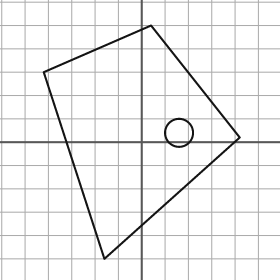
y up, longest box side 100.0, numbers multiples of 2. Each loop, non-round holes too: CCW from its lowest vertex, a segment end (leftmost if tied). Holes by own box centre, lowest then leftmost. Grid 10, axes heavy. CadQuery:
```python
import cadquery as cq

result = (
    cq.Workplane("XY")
    .moveTo(-16.0, -50.0)
    .lineTo(42.0, 2.0)
    .lineTo(4.0, 50.0)
    .lineTo(-42.0, 30.0)
    .close()
    .moveTo(16.0, 4.0)
    .circle(6.0)
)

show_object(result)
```